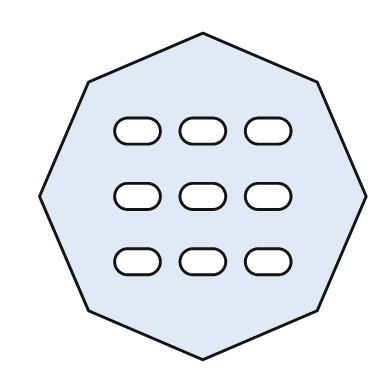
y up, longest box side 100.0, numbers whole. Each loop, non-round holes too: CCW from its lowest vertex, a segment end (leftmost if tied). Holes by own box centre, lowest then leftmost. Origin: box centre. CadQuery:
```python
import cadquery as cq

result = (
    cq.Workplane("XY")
    .moveTo(0.0, -50.0)
    .lineTo(35.0, -35.0)
    .lineTo(50.0, 0.0)
    .lineTo(35.0, 35.0)
    .lineTo(0.0, 50.0)
    .lineTo(-35.0, 35.0)
    .lineTo(-50.0, 0.0)
    .lineTo(-35.0, -35.0)
    .close()
    .moveTo(-23.0, -24.0)
    .lineTo(-17.0, -24.0)
    .threePointArc((-13.0, -20.0), (-17.0, -16.0))
    .lineTo(-23.0, -16.0)
    .threePointArc((-27.0, -20.0), (-23.0, -24.0))
    .close()
    .moveTo(-3.0, -24.0)
    .lineTo(3.0, -24.0)
    .threePointArc((7.0, -20.0), (3.0, -16.0))
    .lineTo(-3.0, -16.0)
    .threePointArc((-7.0, -20.0), (-3.0, -24.0))
    .close()
    .moveTo(17.0, -24.0)
    .lineTo(23.0, -24.0)
    .threePointArc((27.0, -20.0), (23.0, -16.0))
    .lineTo(17.0, -16.0)
    .threePointArc((13.0, -20.0), (17.0, -24.0))
    .close()
    .moveTo(-23.0, -4.0)
    .lineTo(-17.0, -4.0)
    .threePointArc((-13.0, 0.0), (-17.0, 4.0))
    .lineTo(-23.0, 4.0)
    .threePointArc((-27.0, 0.0), (-23.0, -4.0))
    .close()
    .moveTo(-3.0, -4.0)
    .lineTo(3.0, -4.0)
    .threePointArc((7.0, 0.0), (3.0, 4.0))
    .lineTo(-3.0, 4.0)
    .threePointArc((-7.0, 0.0), (-3.0, -4.0))
    .close()
    .moveTo(17.0, -4.0)
    .lineTo(23.0, -4.0)
    .threePointArc((27.0, 0.0), (23.0, 4.0))
    .lineTo(17.0, 4.0)
    .threePointArc((13.0, 0.0), (17.0, -4.0))
    .close()
    .moveTo(-23.0, 16.0)
    .lineTo(-17.0, 16.0)
    .threePointArc((-13.0, 20.0), (-17.0, 24.0))
    .lineTo(-23.0, 24.0)
    .threePointArc((-27.0, 20.0), (-23.0, 16.0))
    .close()
    .moveTo(-3.0, 16.0)
    .lineTo(3.0, 16.0)
    .threePointArc((7.0, 20.0), (3.0, 24.0))
    .lineTo(-3.0, 24.0)
    .threePointArc((-7.0, 20.0), (-3.0, 16.0))
    .close()
    .moveTo(17.0, 16.0)
    .lineTo(23.0, 16.0)
    .threePointArc((27.0, 20.0), (23.0, 24.0))
    .lineTo(17.0, 24.0)
    .threePointArc((13.0, 20.0), (17.0, 16.0))
    .close()
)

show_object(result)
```